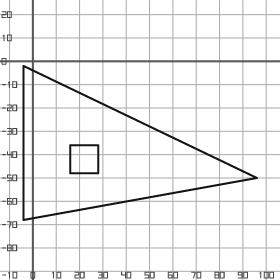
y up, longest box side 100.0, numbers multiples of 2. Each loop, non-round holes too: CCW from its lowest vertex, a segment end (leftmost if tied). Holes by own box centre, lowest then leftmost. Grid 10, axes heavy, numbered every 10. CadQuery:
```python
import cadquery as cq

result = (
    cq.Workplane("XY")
    .moveTo(-4.0, -68.0)
    .lineTo(96.0, -50.0)
    .lineTo(-4.0, -2.0)
    .close()
    .moveTo(16.0, -48.0)
    .lineTo(28.0, -48.0)
    .lineTo(28.0, -36.0)
    .lineTo(16.0, -36.0)
    .close()
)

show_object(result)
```